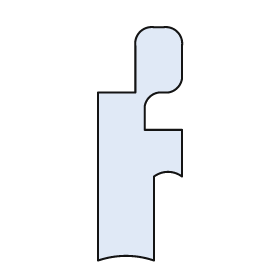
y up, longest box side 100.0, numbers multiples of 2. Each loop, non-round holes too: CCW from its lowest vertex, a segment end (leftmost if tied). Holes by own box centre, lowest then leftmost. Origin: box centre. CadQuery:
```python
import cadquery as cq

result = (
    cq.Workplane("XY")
    .moveTo(-18.0, -50.0)
    .threePointArc((-6.0, -48.0), (6.0, -50.0))
    .lineTo(6.0, -14.0)
    .threePointArc((12.0, -12.0), (18.0, -14.0))
    .lineTo(18.0, 6.0)
    .lineTo(2.0, 6.0)
    .lineTo(2.0, 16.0)
    .threePointArc((4.0, 20.0), (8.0, 22.0))
    .lineTo(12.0, 22.0)
    .threePointArc((16.0, 24.0), (18.0, 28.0))
    .lineTo(18.0, 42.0)
    .threePointArc((16.0, 48.0), (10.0, 50.0))
    .lineTo(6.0, 50.0)
    .threePointArc((0.0, 48.0), (-2.0, 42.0))
    .lineTo(-2.0, 22.0)
    .lineTo(-18.0, 22.0)
    .close()
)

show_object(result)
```